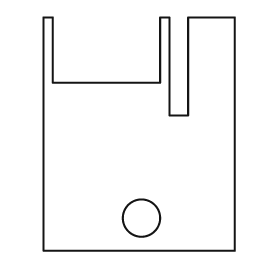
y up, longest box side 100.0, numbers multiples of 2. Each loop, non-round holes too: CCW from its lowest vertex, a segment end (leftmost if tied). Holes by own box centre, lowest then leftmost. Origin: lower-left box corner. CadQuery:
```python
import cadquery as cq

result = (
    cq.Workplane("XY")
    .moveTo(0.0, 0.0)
    .lineTo(82.0, 0.0)
    .lineTo(82.0, 100.0)
    .lineTo(62.0, 100.0)
    .lineTo(62.0, 58.0)
    .lineTo(54.0, 58.0)
    .lineTo(54.0, 100.0)
    .lineTo(50.0, 100.0)
    .lineTo(50.0, 72.0)
    .lineTo(4.0, 72.0)
    .lineTo(4.0, 100.0)
    .lineTo(0.0, 100.0)
    .close()
    .moveTo(42.0, 14.0)
    .circle(8.0)
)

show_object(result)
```